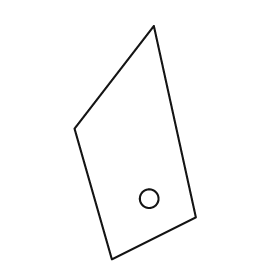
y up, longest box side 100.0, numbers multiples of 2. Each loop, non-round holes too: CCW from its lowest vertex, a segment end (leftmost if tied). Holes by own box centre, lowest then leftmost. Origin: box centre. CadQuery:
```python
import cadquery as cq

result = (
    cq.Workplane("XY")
    .moveTo(-10.0, -50.0)
    .lineTo(26.0, -32.0)
    .lineTo(8.0, 50.0)
    .lineTo(-26.0, 6.0)
    .close()
    .moveTo(6.0, -24.0)
    .circle(4.0)
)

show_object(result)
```